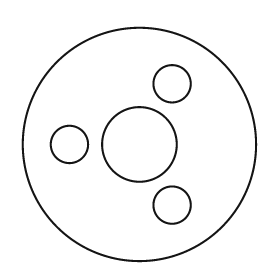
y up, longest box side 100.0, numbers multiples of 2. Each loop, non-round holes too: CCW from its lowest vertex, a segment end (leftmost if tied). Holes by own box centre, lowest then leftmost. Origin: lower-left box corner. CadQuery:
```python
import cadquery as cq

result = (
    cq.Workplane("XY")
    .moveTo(50.0, 50.0)
    .circle(50.0)
    .moveTo(64.0, 24.0)
    .circle(8.0)
    .moveTo(20.0, 50.0)
    .circle(8.0)
    .moveTo(50.0, 50.0)
    .circle(16.0)
    .moveTo(64.0, 76.0)
    .circle(8.0)
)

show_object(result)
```